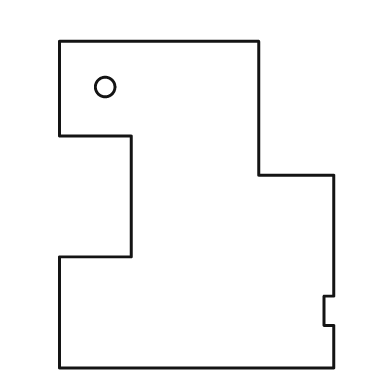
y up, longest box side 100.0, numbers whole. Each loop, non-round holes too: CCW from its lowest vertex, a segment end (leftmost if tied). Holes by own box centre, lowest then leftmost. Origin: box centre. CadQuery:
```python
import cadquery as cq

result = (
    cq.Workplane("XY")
    .moveTo(-42.0, -50.0)
    .lineTo(42.0, -50.0)
    .lineTo(42.0, -37.0)
    .lineTo(39.0, -37.0)
    .lineTo(39.0, -28.0)
    .lineTo(42.0, -28.0)
    .lineTo(42.0, 9.0)
    .lineTo(19.0, 9.0)
    .lineTo(19.0, 50.0)
    .lineTo(-42.0, 50.0)
    .lineTo(-42.0, 21.0)
    .lineTo(-20.0, 21.0)
    .lineTo(-20.0, -16.0)
    .lineTo(-42.0, -16.0)
    .close()
    .moveTo(-28.0, 36.0)
    .circle(3.0)
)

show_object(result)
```